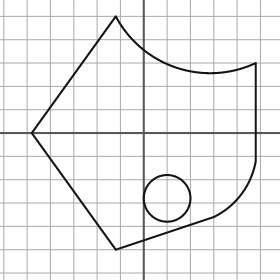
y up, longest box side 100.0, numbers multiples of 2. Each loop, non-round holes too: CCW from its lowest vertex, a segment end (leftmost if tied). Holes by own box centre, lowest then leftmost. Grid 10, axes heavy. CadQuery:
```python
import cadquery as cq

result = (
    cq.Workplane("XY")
    .moveTo(-12.0, -50.0)
    .lineTo(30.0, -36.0)
    .threePointArc((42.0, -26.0), (48.0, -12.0))
    .lineTo(48.0, 30.0)
    .threePointArc((14.0, 28.0), (-12.0, 50.0))
    .lineTo(-48.0, 0.0)
    .close()
    .moveTo(10.0, -28.0)
    .circle(10.0)
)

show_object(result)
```